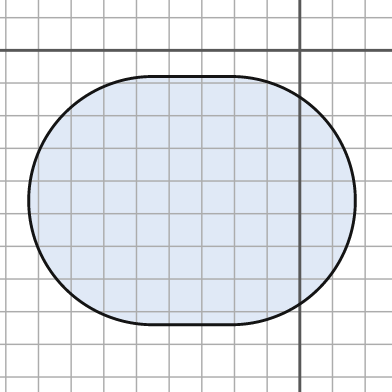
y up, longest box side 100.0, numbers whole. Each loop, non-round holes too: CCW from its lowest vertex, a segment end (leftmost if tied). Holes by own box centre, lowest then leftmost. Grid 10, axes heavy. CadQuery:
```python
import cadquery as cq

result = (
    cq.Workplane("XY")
    .moveTo(-45.0, -84.0)
    .lineTo(-21.0, -84.0)
    .threePointArc((17.0, -46.0), (-21.0, -8.0))
    .lineTo(-45.0, -8.0)
    .threePointArc((-83.0, -46.0), (-45.0, -84.0))
    .close()
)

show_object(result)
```